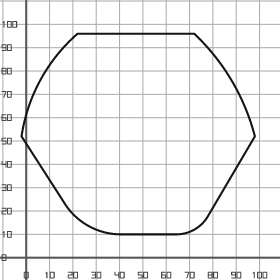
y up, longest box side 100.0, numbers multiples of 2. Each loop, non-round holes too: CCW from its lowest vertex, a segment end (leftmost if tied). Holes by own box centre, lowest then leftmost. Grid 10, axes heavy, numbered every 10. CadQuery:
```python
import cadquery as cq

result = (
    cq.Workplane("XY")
    .moveTo(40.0, 10.0)
    .lineTo(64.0, 10.0)
    .threePointArc((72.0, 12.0), (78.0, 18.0))
    .lineTo(98.0, 52.0)
    .threePointArc((88.0, 76.0), (72.0, 96.0))
    .lineTo(22.0, 96.0)
    .threePointArc((6.0, 76.0), (-2.0, 52.0))
    .lineTo(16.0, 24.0)
    .threePointArc((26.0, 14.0), (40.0, 10.0))
    .close()
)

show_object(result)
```